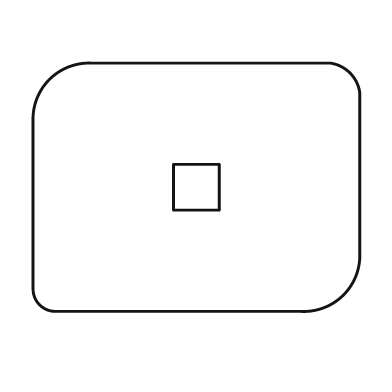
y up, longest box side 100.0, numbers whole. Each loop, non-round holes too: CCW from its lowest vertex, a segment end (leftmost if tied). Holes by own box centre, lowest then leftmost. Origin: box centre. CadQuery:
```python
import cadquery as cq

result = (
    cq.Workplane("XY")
    .moveTo(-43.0, -38.0)
    .lineTo(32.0, -38.0)
    .threePointArc((45.0, -33.0), (50.0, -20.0))
    .lineTo(50.0, 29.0)
    .threePointArc((47.0, 35.0), (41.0, 38.0))
    .lineTo(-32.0, 38.0)
    .threePointArc((-45.0, 33.0), (-50.0, 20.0))
    .lineTo(-50.0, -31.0)
    .threePointArc((-48.0, -36.0), (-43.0, -38.0))
    .close()
    .moveTo(-7.0, -7.0)
    .lineTo(7.0, -7.0)
    .lineTo(7.0, 7.0)
    .lineTo(-7.0, 7.0)
    .close()
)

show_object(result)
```